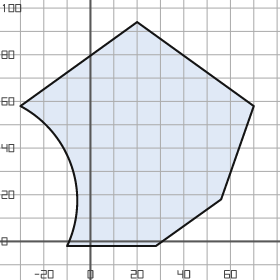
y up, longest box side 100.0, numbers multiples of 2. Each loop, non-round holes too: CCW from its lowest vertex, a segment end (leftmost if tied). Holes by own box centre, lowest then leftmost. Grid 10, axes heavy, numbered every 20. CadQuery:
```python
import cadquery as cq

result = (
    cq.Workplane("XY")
    .moveTo(-10.0, -2.0)
    .lineTo(28.0, -2.0)
    .lineTo(56.0, 18.0)
    .lineTo(70.0, 58.0)
    .lineTo(20.0, 94.0)
    .lineTo(-30.0, 58.0)
    .threePointArc((-8.0, 32.0), (-10.0, -2.0))
    .close()
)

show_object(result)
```